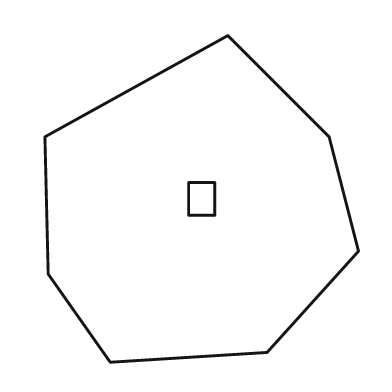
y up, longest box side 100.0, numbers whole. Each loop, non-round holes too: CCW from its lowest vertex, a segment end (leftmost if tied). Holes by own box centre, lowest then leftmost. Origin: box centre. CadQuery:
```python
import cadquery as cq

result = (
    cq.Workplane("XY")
    .moveTo(-28.0, -50.0)
    .lineTo(20.0, -47.0)
    .lineTo(48.0, -16.0)
    .lineTo(39.0, 19.0)
    .lineTo(8.0, 50.0)
    .lineTo(-48.0, 19.0)
    .lineTo(-47.0, -23.0)
    .close()
    .moveTo(-4.0, -5.0)
    .lineTo(4.0, -5.0)
    .lineTo(4.0, 5.0)
    .lineTo(-4.0, 5.0)
    .close()
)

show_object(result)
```